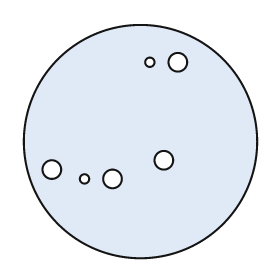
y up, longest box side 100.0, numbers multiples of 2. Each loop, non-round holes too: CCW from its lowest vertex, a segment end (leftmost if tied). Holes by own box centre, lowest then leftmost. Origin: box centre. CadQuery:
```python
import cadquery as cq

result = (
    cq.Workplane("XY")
    .moveTo(0.0, 0.0)
    .circle(50.0)
    .moveTo(-24.0, -16.0)
    .circle(2.0)
    .moveTo(-12.0, -16.0)
    .circle(4.0)
    .moveTo(-38.0, -12.0)
    .circle(4.0)
    .moveTo(10.0, -8.0)
    .circle(4.0)
    .moveTo(4.0, 34.0)
    .circle(2.0)
    .moveTo(16.0, 34.0)
    .circle(4.0)
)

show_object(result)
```